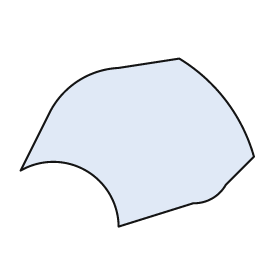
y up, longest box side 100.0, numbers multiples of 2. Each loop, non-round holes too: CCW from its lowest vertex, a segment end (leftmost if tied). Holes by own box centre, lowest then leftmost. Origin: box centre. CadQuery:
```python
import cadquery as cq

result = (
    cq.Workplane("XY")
    .moveTo(-8.0, -36.0)
    .lineTo(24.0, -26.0)
    .threePointArc((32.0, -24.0), (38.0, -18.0))
    .lineTo(50.0, -6.0)
    .threePointArc((38.0, 18.0), (18.0, 36.0))
    .lineTo(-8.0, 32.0)
    .threePointArc((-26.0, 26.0), (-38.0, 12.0))
    .lineTo(-50.0, -12.0)
    .threePointArc((-22.0, -12.0), (-8.0, -36.0))
    .close()
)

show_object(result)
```